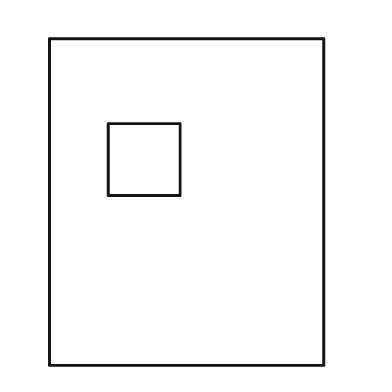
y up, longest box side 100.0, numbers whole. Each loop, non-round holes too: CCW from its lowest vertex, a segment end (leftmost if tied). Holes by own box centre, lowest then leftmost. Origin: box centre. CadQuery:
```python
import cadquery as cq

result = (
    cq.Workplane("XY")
    .moveTo(-42.0, -50.0)
    .lineTo(42.0, -50.0)
    .lineTo(42.0, 50.0)
    .lineTo(-42.0, 50.0)
    .close()
    .moveTo(-24.0, 2.0)
    .lineTo(-2.0, 2.0)
    .lineTo(-2.0, 24.0)
    .lineTo(-24.0, 24.0)
    .close()
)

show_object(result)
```